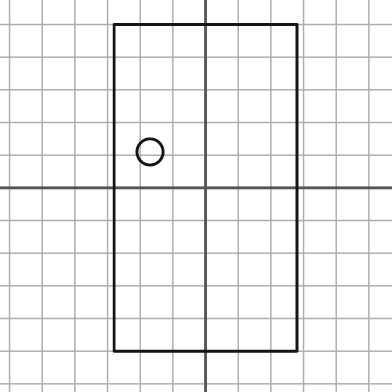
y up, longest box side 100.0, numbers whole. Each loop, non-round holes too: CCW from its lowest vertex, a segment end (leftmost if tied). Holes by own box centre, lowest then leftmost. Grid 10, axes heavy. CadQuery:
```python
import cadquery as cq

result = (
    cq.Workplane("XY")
    .moveTo(-28.0, -50.0)
    .lineTo(28.0, -50.0)
    .lineTo(28.0, 50.0)
    .lineTo(-28.0, 50.0)
    .close()
    .moveTo(-17.0, 11.0)
    .circle(4.0)
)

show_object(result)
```